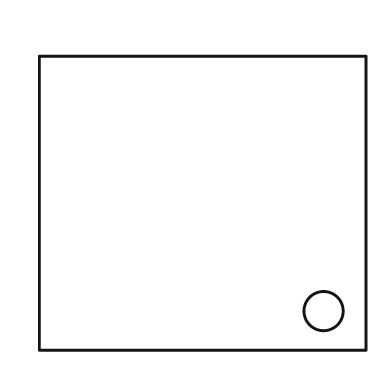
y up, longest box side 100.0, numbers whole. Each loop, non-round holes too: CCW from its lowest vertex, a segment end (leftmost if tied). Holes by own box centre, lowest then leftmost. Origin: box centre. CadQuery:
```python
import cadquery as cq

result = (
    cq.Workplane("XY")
    .moveTo(-50.0, -45.0)
    .lineTo(50.0, -45.0)
    .lineTo(50.0, 45.0)
    .lineTo(-50.0, 45.0)
    .close()
    .moveTo(37.0, -33.0)
    .circle(6.0)
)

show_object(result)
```